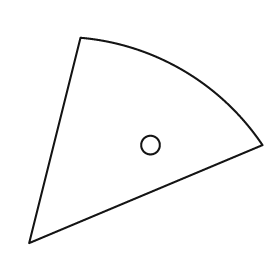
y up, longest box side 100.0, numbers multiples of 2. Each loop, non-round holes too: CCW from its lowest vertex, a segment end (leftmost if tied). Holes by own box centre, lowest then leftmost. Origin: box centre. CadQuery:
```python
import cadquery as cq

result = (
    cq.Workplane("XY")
    .moveTo(-50.0, -44.0)
    .lineTo(50.0, -2.0)
    .threePointArc((16.0, 30.0), (-28.0, 44.0))
    .close()
    .moveTo(2.0, -2.0)
    .circle(4.0)
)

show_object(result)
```